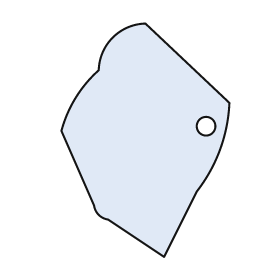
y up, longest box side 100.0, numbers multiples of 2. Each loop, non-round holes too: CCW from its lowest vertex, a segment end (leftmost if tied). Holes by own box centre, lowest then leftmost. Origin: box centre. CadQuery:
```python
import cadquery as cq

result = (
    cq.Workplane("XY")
    .moveTo(8.0, -50.0)
    .lineTo(22.0, -22.0)
    .threePointArc((32.0, -4.0), (36.0, 16.0))
    .lineTo(0.0, 50.0)
    .threePointArc((-14.0, 44.0), (-20.0, 30.0))
    .threePointArc((-30.0, 18.0), (-36.0, 4.0))
    .lineTo(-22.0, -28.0)
    .threePointArc((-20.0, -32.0), (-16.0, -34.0))
    .close()
    .moveTo(26.0, 6.0)
    .circle(4.0)
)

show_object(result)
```